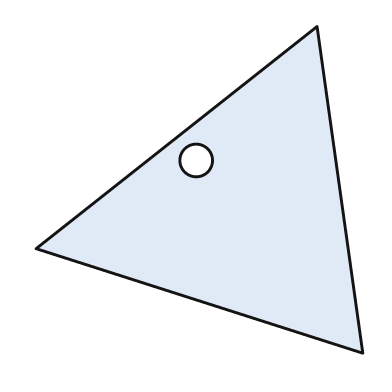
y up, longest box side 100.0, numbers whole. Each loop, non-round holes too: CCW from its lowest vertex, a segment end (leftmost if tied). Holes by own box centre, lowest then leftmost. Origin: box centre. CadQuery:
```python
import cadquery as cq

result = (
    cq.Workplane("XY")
    .moveTo(50.0, -50.0)
    .lineTo(36.0, 50.0)
    .lineTo(-50.0, -18.0)
    .close()
    .moveTo(-1.0, 9.0)
    .circle(5.0)
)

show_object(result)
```